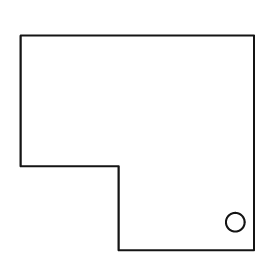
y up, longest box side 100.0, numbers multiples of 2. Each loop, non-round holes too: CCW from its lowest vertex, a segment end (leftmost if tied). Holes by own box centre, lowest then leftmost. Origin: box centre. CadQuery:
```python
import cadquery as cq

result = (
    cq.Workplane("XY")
    .moveTo(-8.0, -46.0)
    .lineTo(50.0, -46.0)
    .lineTo(50.0, 46.0)
    .lineTo(-50.0, 46.0)
    .lineTo(-50.0, -10.0)
    .lineTo(-8.0, -10.0)
    .close()
    .moveTo(42.0, -34.0)
    .circle(4.0)
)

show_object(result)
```